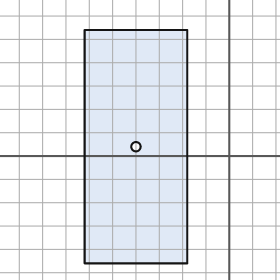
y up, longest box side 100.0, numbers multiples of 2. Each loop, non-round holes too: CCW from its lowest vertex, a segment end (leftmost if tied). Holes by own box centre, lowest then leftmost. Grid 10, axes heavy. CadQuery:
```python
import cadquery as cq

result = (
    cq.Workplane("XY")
    .moveTo(-62.0, -46.0)
    .lineTo(-18.0, -46.0)
    .lineTo(-18.0, 54.0)
    .lineTo(-62.0, 54.0)
    .close()
    .moveTo(-40.0, 4.0)
    .circle(2.0)
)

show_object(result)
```